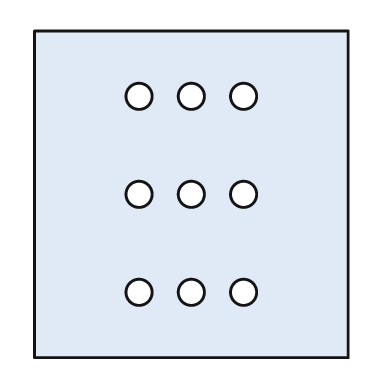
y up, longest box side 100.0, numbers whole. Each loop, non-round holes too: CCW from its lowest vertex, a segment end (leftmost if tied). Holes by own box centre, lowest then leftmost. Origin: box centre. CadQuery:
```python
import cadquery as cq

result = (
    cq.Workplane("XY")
    .moveTo(-48.0, -50.0)
    .lineTo(48.0, -50.0)
    .lineTo(48.0, 50.0)
    .lineTo(-48.0, 50.0)
    .close()
    .moveTo(-16.0, -30.0)
    .circle(4.0)
    .moveTo(0.0, -30.0)
    .circle(4.0)
    .moveTo(16.0, -30.0)
    .circle(4.0)
    .moveTo(-16.0, 0.0)
    .circle(4.0)
    .moveTo(0.0, 0.0)
    .circle(4.0)
    .moveTo(16.0, 0.0)
    .circle(4.0)
    .moveTo(-16.0, 30.0)
    .circle(4.0)
    .moveTo(0.0, 30.0)
    .circle(4.0)
    .moveTo(16.0, 30.0)
    .circle(4.0)
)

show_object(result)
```